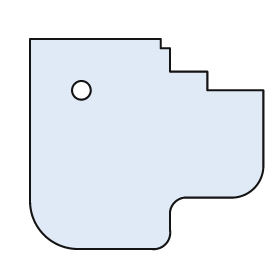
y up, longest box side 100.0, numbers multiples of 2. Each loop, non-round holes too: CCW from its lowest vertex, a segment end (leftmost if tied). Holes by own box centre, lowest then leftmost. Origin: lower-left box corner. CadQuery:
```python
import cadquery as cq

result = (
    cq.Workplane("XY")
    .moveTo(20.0, 0.0)
    .lineTo(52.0, 0.0)
    .threePointArc((58.0, 2.0), (60.0, 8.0))
    .lineTo(60.0, 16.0)
    .threePointArc((62.0, 20.0), (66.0, 22.0))
    .lineTo(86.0, 22.0)
    .threePointArc((96.0, 26.0), (100.0, 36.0))
    .lineTo(100.0, 68.0)
    .lineTo(76.0, 68.0)
    .lineTo(76.0, 76.0)
    .lineTo(60.0, 76.0)
    .lineTo(60.0, 86.0)
    .lineTo(56.0, 86.0)
    .lineTo(56.0, 90.0)
    .lineTo(0.0, 90.0)
    .lineTo(0.0, 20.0)
    .threePointArc((6.0, 6.0), (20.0, 0.0))
    .close()
    .moveTo(22.0, 68.0)
    .circle(4.0)
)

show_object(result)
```